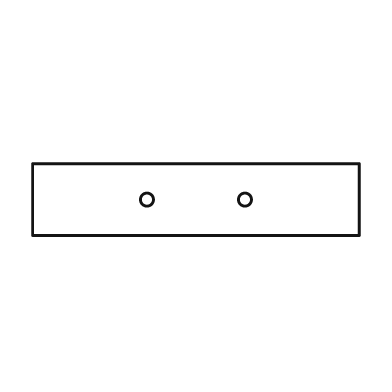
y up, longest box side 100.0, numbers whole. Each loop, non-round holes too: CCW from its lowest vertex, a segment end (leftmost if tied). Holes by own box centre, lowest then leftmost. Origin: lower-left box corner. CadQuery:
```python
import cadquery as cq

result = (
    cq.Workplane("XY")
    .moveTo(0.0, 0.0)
    .lineTo(100.0, 0.0)
    .lineTo(100.0, 22.0)
    .lineTo(0.0, 22.0)
    .close()
    .moveTo(35.0, 11.0)
    .circle(2.0)
    .moveTo(65.0, 11.0)
    .circle(2.0)
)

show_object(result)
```